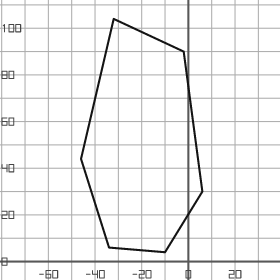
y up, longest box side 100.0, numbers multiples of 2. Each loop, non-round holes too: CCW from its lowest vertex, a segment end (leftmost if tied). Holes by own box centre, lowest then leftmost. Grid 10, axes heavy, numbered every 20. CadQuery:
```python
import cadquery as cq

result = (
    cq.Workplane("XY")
    .moveTo(-10.0, 4.0)
    .lineTo(6.0, 30.0)
    .lineTo(-2.0, 90.0)
    .lineTo(-32.0, 104.0)
    .lineTo(-46.0, 44.0)
    .lineTo(-34.0, 6.0)
    .close()
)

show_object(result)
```